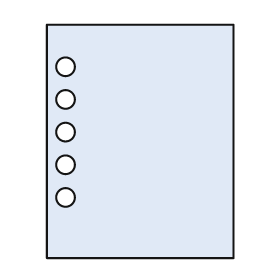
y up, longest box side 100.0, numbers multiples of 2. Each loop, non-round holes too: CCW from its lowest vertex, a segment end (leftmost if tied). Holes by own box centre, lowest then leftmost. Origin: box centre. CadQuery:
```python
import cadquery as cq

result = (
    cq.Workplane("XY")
    .moveTo(-40.0, -50.0)
    .lineTo(40.0, -50.0)
    .lineTo(40.0, 50.0)
    .lineTo(-40.0, 50.0)
    .close()
    .moveTo(-32.0, -24.0)
    .circle(4.0)
    .moveTo(-32.0, -10.0)
    .circle(4.0)
    .moveTo(-32.0, 4.0)
    .circle(4.0)
    .moveTo(-32.0, 18.0)
    .circle(4.0)
    .moveTo(-32.0, 32.0)
    .circle(4.0)
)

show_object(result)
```